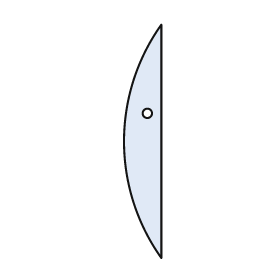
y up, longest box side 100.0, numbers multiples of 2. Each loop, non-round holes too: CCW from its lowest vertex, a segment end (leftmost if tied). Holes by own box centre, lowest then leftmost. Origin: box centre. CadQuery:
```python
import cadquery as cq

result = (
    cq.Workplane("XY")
    .moveTo(8.0, -50.0)
    .lineTo(8.0, 50.0)
    .threePointArc((-8.0, 0.0), (8.0, -50.0))
    .close()
    .moveTo(2.0, 12.0)
    .circle(2.0)
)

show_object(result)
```